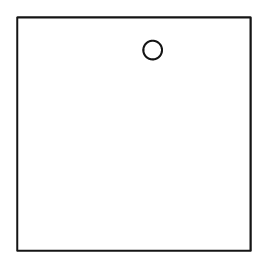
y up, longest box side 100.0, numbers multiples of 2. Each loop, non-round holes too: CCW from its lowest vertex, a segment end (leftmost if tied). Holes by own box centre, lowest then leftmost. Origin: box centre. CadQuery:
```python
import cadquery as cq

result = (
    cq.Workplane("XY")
    .moveTo(-50.0, -50.0)
    .lineTo(50.0, -50.0)
    .lineTo(50.0, 50.0)
    .lineTo(-50.0, 50.0)
    .close()
    .moveTo(8.0, 36.0)
    .circle(4.0)
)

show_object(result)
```